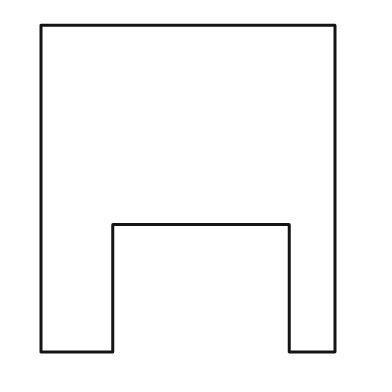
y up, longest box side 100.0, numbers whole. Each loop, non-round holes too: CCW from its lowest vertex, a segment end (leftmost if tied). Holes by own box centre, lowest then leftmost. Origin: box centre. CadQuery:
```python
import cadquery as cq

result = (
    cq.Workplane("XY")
    .moveTo(-45.0, -50.0)
    .lineTo(-23.0, -50.0)
    .lineTo(-23.0, -11.0)
    .lineTo(31.0, -11.0)
    .lineTo(31.0, -50.0)
    .lineTo(45.0, -50.0)
    .lineTo(45.0, 50.0)
    .lineTo(-45.0, 50.0)
    .close()
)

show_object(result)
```